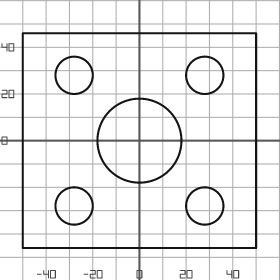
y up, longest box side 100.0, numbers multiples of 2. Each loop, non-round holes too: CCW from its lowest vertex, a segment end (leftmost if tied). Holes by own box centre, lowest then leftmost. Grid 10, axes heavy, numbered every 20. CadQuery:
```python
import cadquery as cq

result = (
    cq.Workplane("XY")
    .moveTo(-50.0, -46.0)
    .lineTo(50.0, -46.0)
    .lineTo(50.0, 46.0)
    .lineTo(-50.0, 46.0)
    .close()
    .moveTo(-28.0, -28.0)
    .circle(8.0)
    .moveTo(28.0, -28.0)
    .circle(8.0)
    .moveTo(0.0, 0.0)
    .circle(18.0)
    .moveTo(-28.0, 28.0)
    .circle(8.0)
    .moveTo(28.0, 28.0)
    .circle(8.0)
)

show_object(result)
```